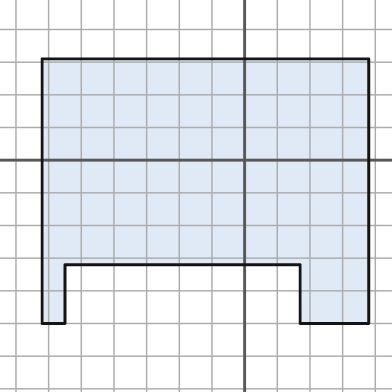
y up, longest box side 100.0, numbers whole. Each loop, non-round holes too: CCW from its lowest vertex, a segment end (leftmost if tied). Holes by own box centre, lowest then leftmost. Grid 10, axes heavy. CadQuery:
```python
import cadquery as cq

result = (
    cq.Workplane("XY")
    .moveTo(-62.0, -50.0)
    .lineTo(-55.0, -50.0)
    .lineTo(-55.0, -32.0)
    .lineTo(17.0, -32.0)
    .lineTo(17.0, -50.0)
    .lineTo(38.0, -50.0)
    .lineTo(38.0, 31.0)
    .lineTo(-62.0, 31.0)
    .close()
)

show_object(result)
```